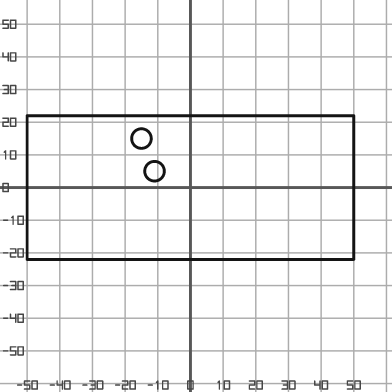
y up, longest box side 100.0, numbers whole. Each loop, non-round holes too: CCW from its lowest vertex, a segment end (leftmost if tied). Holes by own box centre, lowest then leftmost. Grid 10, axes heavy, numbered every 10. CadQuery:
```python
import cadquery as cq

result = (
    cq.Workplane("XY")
    .moveTo(-50.0, -22.0)
    .lineTo(50.0, -22.0)
    .lineTo(50.0, 22.0)
    .lineTo(-50.0, 22.0)
    .close()
    .moveTo(-11.0, 5.0)
    .circle(3.0)
    .moveTo(-15.0, 15.0)
    .circle(3.0)
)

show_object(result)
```